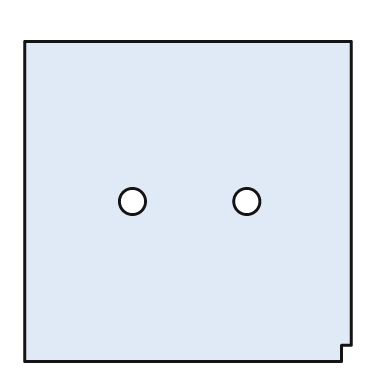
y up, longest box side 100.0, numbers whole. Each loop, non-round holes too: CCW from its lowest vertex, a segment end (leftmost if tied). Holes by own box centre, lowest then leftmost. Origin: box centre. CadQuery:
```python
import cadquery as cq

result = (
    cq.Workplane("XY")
    .moveTo(-50.0, -49.0)
    .lineTo(47.0, -49.0)
    .lineTo(47.0, -44.0)
    .lineTo(50.0, -44.0)
    .lineTo(50.0, 49.0)
    .lineTo(-50.0, 49.0)
    .close()
    .moveTo(-17.0, 0.0)
    .circle(4.0)
    .moveTo(18.0, 0.0)
    .circle(4.0)
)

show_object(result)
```